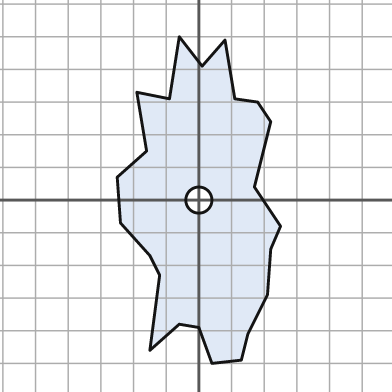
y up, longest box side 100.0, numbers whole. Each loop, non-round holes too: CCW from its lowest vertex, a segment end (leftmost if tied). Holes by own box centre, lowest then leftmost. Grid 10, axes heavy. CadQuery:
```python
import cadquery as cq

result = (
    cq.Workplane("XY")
    .moveTo(4.0, -50.0)
    .lineTo(13.0, -49.0)
    .lineTo(15.0, -41.0)
    .lineTo(21.0, -29.0)
    .lineTo(22.0, -15.0)
    .lineTo(25.0, -8.0)
    .lineTo(17.0, 4.0)
    .lineTo(22.0, 24.0)
    .lineTo(18.0, 30.0)
    .lineTo(11.0, 31.0)
    .lineTo(8.0, 49.0)
    .lineTo(1.0, 41.0)
    .lineTo(-6.0, 50.0)
    .lineTo(-9.0, 31.0)
    .lineTo(-19.0, 33.0)
    .lineTo(-16.0, 15.0)
    .lineTo(-25.0, 7.0)
    .lineTo(-24.0, -7.0)
    .lineTo(-15.0, -17.0)
    .lineTo(-12.0, -23.0)
    .lineTo(-15.0, -46.0)
    .lineTo(-6.0, -38.0)
    .lineTo(0.0, -39.0)
    .close()
    .moveTo(0.0, 0.0)
    .circle(4.0)
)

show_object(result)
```